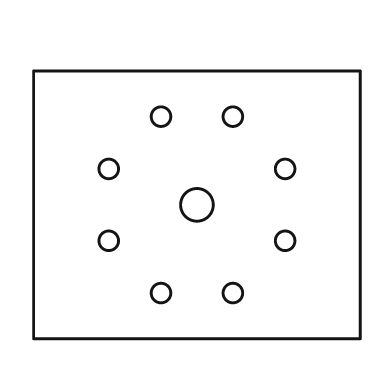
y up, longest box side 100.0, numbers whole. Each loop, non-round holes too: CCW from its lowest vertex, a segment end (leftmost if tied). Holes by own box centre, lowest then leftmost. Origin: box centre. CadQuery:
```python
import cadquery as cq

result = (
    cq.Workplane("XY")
    .moveTo(-50.0, -41.0)
    .lineTo(50.0, -41.0)
    .lineTo(50.0, 41.0)
    .lineTo(-50.0, 41.0)
    .close()
    .moveTo(-11.0, -27.0)
    .circle(3.0)
    .moveTo(11.0, -27.0)
    .circle(3.0)
    .moveTo(-27.0, -11.0)
    .circle(3.0)
    .moveTo(27.0, -11.0)
    .circle(3.0)
    .moveTo(0.0, 0.0)
    .circle(5.0)
    .moveTo(-27.0, 11.0)
    .circle(3.0)
    .moveTo(27.0, 11.0)
    .circle(3.0)
    .moveTo(-11.0, 27.0)
    .circle(3.0)
    .moveTo(11.0, 27.0)
    .circle(3.0)
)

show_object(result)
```